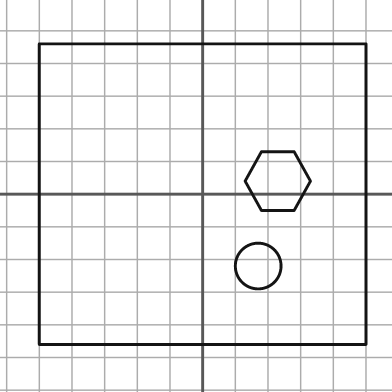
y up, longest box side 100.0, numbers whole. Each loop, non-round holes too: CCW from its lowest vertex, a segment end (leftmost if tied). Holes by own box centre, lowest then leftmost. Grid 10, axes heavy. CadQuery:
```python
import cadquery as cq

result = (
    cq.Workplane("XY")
    .moveTo(-50.0, -46.0)
    .lineTo(50.0, -46.0)
    .lineTo(50.0, 46.0)
    .lineTo(-50.0, 46.0)
    .close()
    .moveTo(17.0, -22.0)
    .circle(7.0)
    .moveTo(18.0, -5.0)
    .lineTo(28.0, -5.0)
    .lineTo(33.0, 4.0)
    .lineTo(28.0, 13.0)
    .lineTo(18.0, 13.0)
    .lineTo(13.0, 4.0)
    .close()
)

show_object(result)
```